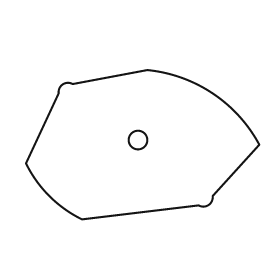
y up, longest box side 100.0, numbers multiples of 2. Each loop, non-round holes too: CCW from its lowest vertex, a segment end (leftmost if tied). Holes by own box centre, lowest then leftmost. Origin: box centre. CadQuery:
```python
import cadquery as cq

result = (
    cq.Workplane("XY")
    .moveTo(-26.0, -32.0)
    .lineTo(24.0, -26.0)
    .threePointArc((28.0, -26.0), (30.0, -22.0))
    .lineTo(50.0, 0.0)
    .threePointArc((30.0, 22.0), (2.0, 32.0))
    .lineTo(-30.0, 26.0)
    .threePointArc((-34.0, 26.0), (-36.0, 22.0))
    .lineTo(-50.0, -8.0)
    .threePointArc((-40.0, -22.0), (-26.0, -32.0))
    .close()
    .moveTo(-2.0, 2.0)
    .circle(4.0)
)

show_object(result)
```